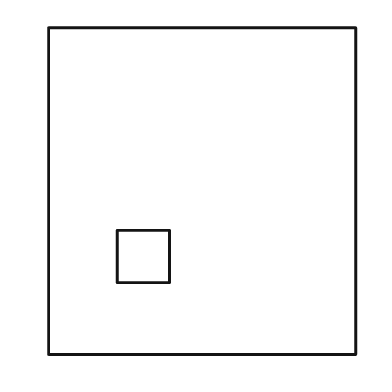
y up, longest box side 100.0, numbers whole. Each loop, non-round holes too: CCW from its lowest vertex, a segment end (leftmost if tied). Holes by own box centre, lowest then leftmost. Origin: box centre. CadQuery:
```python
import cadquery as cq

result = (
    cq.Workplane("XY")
    .moveTo(-47.0, -50.0)
    .lineTo(47.0, -50.0)
    .lineTo(47.0, 50.0)
    .lineTo(-47.0, 50.0)
    .close()
    .moveTo(-26.0, -28.0)
    .lineTo(-10.0, -28.0)
    .lineTo(-10.0, -12.0)
    .lineTo(-26.0, -12.0)
    .close()
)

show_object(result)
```